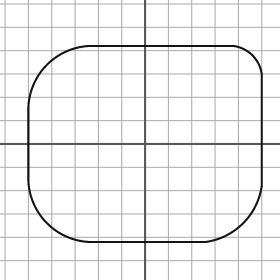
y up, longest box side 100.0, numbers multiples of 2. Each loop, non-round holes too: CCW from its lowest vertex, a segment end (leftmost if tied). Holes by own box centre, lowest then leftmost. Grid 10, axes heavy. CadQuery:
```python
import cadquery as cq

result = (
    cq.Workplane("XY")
    .moveTo(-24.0, -42.0)
    .lineTo(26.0, -42.0)
    .threePointArc((42.0, -34.0), (50.0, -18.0))
    .lineTo(50.0, 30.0)
    .threePointArc((46.0, 38.0), (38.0, 42.0))
    .lineTo(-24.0, 42.0)
    .threePointArc((-42.0, 34.0), (-50.0, 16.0))
    .lineTo(-50.0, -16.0)
    .threePointArc((-42.0, -34.0), (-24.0, -42.0))
    .close()
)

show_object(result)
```